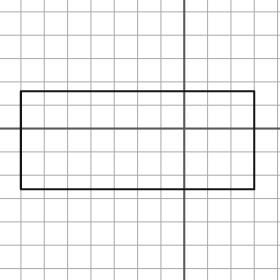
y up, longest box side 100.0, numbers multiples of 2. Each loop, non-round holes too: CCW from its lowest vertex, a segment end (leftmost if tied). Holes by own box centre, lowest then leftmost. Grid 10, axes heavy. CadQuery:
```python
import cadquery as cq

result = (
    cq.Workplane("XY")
    .moveTo(-70.0, -26.0)
    .lineTo(30.0, -26.0)
    .lineTo(30.0, 16.0)
    .lineTo(-70.0, 16.0)
    .close()
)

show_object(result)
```